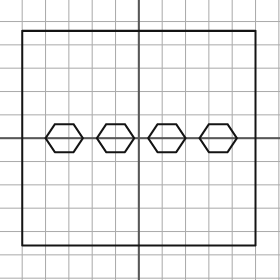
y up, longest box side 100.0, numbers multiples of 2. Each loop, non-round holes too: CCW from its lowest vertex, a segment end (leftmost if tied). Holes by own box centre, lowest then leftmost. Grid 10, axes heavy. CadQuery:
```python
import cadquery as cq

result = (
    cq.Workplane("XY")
    .moveTo(-50.0, -46.0)
    .lineTo(50.0, -46.0)
    .lineTo(50.0, 46.0)
    .lineTo(-50.0, 46.0)
    .close()
    .moveTo(-36.0, -6.0)
    .lineTo(-28.0, -6.0)
    .lineTo(-24.0, 0.0)
    .lineTo(-28.0, 6.0)
    .lineTo(-36.0, 6.0)
    .lineTo(-40.0, 0.0)
    .close()
    .moveTo(-14.0, -6.0)
    .lineTo(-6.0, -6.0)
    .lineTo(-2.0, 0.0)
    .lineTo(-6.0, 6.0)
    .lineTo(-14.0, 6.0)
    .lineTo(-18.0, 0.0)
    .close()
    .moveTo(8.0, -6.0)
    .lineTo(16.0, -6.0)
    .lineTo(20.0, 0.0)
    .lineTo(16.0, 6.0)
    .lineTo(8.0, 6.0)
    .lineTo(4.0, 0.0)
    .close()
    .moveTo(30.0, -6.0)
    .lineTo(38.0, -6.0)
    .lineTo(42.0, 0.0)
    .lineTo(38.0, 6.0)
    .lineTo(30.0, 6.0)
    .lineTo(26.0, 0.0)
    .close()
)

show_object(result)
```